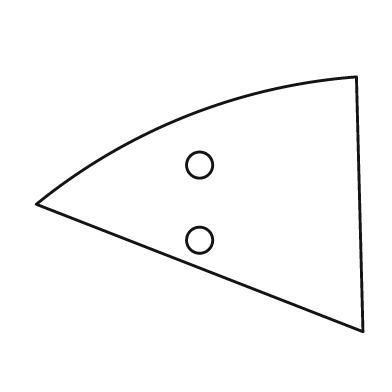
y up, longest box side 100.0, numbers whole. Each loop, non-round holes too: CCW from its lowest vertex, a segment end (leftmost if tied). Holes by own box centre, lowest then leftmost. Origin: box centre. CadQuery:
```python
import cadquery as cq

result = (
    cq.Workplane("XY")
    .moveTo(50.0, -39.0)
    .lineTo(48.0, 39.0)
    .threePointArc((-4.0, 27.0), (-50.0, 0.0))
    .close()
    .moveTo(0.0, -11.0)
    .circle(4.0)
    .moveTo(0.0, 12.0)
    .circle(4.0)
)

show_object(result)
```